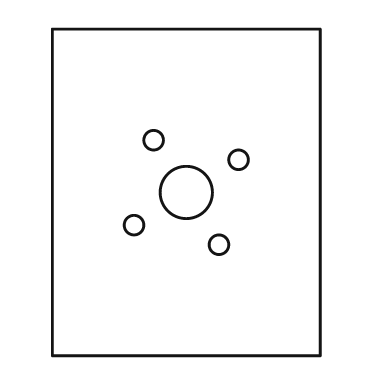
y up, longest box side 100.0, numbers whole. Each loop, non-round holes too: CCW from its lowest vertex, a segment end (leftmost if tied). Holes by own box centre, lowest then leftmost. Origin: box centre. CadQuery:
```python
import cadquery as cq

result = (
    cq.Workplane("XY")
    .moveTo(-41.0, -50.0)
    .lineTo(41.0, -50.0)
    .lineTo(41.0, 50.0)
    .lineTo(-41.0, 50.0)
    .close()
    .moveTo(10.0, -16.0)
    .circle(3.0)
    .moveTo(-16.0, -10.0)
    .circle(3.0)
    .moveTo(0.0, 0.0)
    .circle(8.0)
    .moveTo(16.0, 10.0)
    .circle(3.0)
    .moveTo(-10.0, 16.0)
    .circle(3.0)
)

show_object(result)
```